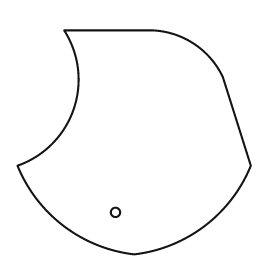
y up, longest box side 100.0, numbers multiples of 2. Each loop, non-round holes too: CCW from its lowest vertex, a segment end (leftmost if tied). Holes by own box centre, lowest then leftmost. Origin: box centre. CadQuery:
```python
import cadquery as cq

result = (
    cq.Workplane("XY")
    .moveTo(0.0, -48.0)
    .threePointArc((30.0, -36.0), (50.0, -10.0))
    .lineTo(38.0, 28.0)
    .threePointArc((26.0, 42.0), (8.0, 48.0))
    .lineTo(-30.0, 48.0)
    .threePointArc((-26.0, 14.0), (-50.0, -10.0))
    .threePointArc((-30.0, -36.0), (0.0, -48.0))
    .close()
    .moveTo(-8.0, -30.0)
    .circle(2.0)
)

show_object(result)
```